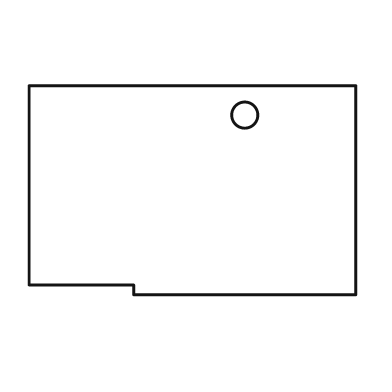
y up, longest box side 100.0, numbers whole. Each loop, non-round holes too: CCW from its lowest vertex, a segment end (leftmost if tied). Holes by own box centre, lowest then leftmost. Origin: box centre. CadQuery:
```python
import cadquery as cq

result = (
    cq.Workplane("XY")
    .moveTo(-18.0, -32.0)
    .lineTo(50.0, -32.0)
    .lineTo(50.0, 32.0)
    .lineTo(-50.0, 32.0)
    .lineTo(-50.0, -29.0)
    .lineTo(-18.0, -29.0)
    .close()
    .moveTo(16.0, 23.0)
    .circle(4.0)
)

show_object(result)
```